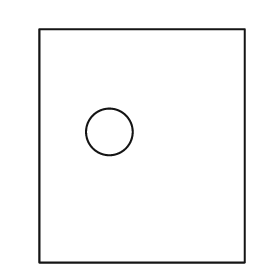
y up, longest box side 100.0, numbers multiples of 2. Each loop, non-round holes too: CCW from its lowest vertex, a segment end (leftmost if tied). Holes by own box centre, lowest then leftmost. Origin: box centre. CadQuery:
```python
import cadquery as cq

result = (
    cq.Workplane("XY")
    .moveTo(-44.0, -50.0)
    .lineTo(44.0, -50.0)
    .lineTo(44.0, 50.0)
    .lineTo(-44.0, 50.0)
    .close()
    .moveTo(-14.0, 6.0)
    .circle(10.0)
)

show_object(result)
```